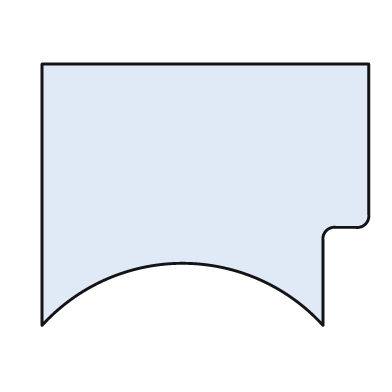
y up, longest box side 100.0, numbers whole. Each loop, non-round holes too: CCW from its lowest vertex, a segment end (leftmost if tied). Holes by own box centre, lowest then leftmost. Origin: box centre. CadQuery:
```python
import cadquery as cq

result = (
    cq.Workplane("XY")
    .moveTo(-50.0, -40.0)
    .threePointArc((-7.0, -21.0), (36.0, -40.0))
    .lineTo(36.0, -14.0)
    .threePointArc((37.0, -11.0), (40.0, -10.0))
    .lineTo(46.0, -10.0)
    .threePointArc((49.0, -9.0), (50.0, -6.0))
    .lineTo(50.0, 40.0)
    .lineTo(-50.0, 40.0)
    .close()
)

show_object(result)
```